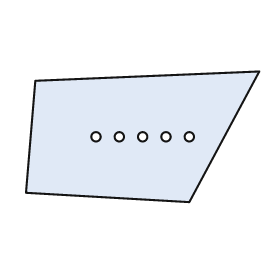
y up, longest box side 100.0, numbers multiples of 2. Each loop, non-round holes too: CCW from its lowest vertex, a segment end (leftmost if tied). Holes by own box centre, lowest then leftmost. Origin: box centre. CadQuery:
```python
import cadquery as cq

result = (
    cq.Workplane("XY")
    .moveTo(20.0, -28.0)
    .lineTo(50.0, 28.0)
    .lineTo(-46.0, 24.0)
    .lineTo(-50.0, -24.0)
    .close()
    .moveTo(-20.0, 0.0)
    .circle(2.0)
    .moveTo(-10.0, 0.0)
    .circle(2.0)
    .moveTo(0.0, 0.0)
    .circle(2.0)
    .moveTo(10.0, 0.0)
    .circle(2.0)
    .moveTo(20.0, 0.0)
    .circle(2.0)
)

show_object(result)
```